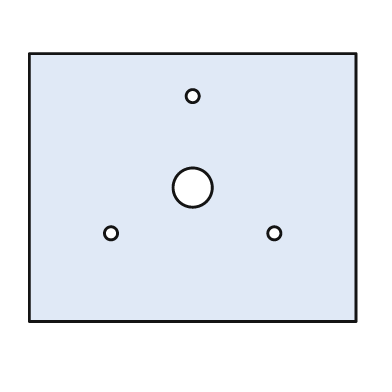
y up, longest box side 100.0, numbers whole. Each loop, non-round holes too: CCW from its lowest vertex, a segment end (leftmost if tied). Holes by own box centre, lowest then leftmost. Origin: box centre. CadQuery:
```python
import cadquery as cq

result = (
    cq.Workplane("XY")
    .moveTo(-50.0, -41.0)
    .lineTo(50.0, -41.0)
    .lineTo(50.0, 41.0)
    .lineTo(-50.0, 41.0)
    .close()
    .moveTo(-25.0, -14.0)
    .circle(2.0)
    .moveTo(25.0, -14.0)
    .circle(2.0)
    .moveTo(0.0, 0.0)
    .circle(6.0)
    .moveTo(0.0, 28.0)
    .circle(2.0)
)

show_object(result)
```